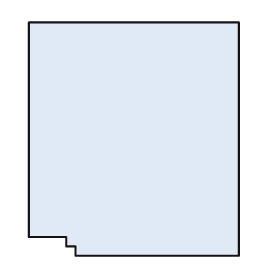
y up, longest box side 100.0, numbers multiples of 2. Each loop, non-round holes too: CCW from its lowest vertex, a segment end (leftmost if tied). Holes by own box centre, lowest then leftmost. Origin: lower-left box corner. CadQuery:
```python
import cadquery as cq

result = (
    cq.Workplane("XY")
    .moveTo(20.0, 0.0)
    .lineTo(90.0, 0.0)
    .lineTo(90.0, 100.0)
    .lineTo(0.0, 100.0)
    .lineTo(0.0, 8.0)
    .lineTo(16.0, 8.0)
    .lineTo(16.0, 4.0)
    .lineTo(20.0, 4.0)
    .close()
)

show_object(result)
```